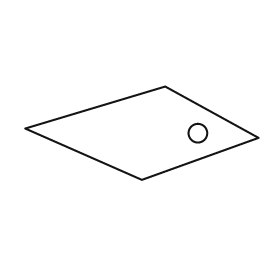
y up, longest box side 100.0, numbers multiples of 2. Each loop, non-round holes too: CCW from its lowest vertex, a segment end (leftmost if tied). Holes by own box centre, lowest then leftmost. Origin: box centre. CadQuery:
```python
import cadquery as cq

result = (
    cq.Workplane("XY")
    .moveTo(0.0, -20.0)
    .lineTo(50.0, -2.0)
    .lineTo(10.0, 20.0)
    .lineTo(-50.0, 2.0)
    .close()
    .moveTo(24.0, 0.0)
    .circle(4.0)
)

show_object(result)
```